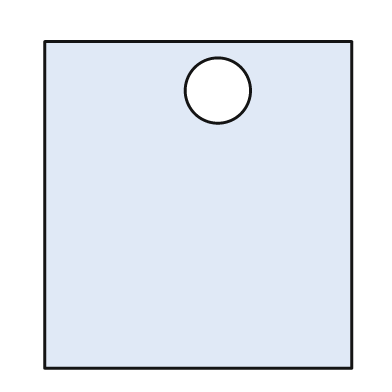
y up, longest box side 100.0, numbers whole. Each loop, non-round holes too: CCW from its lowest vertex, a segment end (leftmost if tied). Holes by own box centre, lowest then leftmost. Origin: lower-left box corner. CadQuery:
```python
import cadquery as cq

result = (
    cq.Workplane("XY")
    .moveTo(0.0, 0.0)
    .lineTo(94.0, 0.0)
    .lineTo(94.0, 100.0)
    .lineTo(0.0, 100.0)
    .close()
    .moveTo(53.0, 85.0)
    .circle(10.0)
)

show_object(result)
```